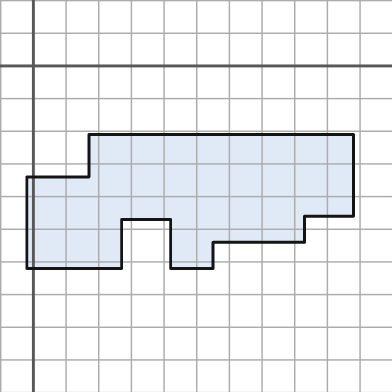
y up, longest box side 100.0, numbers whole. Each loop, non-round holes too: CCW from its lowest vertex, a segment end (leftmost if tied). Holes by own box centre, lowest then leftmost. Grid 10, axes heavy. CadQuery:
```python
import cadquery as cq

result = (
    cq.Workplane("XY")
    .moveTo(-2.0, -62.0)
    .lineTo(27.0, -62.0)
    .lineTo(27.0, -47.0)
    .lineTo(42.0, -47.0)
    .lineTo(42.0, -62.0)
    .lineTo(55.0, -62.0)
    .lineTo(55.0, -54.0)
    .lineTo(83.0, -54.0)
    .lineTo(83.0, -46.0)
    .lineTo(98.0, -46.0)
    .lineTo(98.0, -21.0)
    .lineTo(17.0, -21.0)
    .lineTo(17.0, -34.0)
    .lineTo(-2.0, -34.0)
    .close()
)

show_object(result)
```